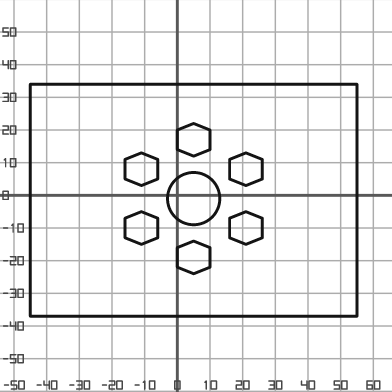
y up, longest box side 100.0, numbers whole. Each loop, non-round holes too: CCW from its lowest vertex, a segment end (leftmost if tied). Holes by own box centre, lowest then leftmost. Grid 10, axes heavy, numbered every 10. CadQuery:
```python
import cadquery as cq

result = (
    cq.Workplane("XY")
    .moveTo(-45.0, -37.0)
    .lineTo(55.0, -37.0)
    .lineTo(55.0, 34.0)
    .lineTo(-45.0, 34.0)
    .close()
    .moveTo(5.0, -24.0)
    .lineTo(10.0, -22.0)
    .lineTo(10.0, -16.0)
    .lineTo(5.0, -14.0)
    .lineTo(0.0, -16.0)
    .lineTo(0.0, -22.0)
    .close()
    .moveTo(-11.0, -15.0)
    .lineTo(-6.0, -13.0)
    .lineTo(-6.0, -7.0)
    .lineTo(-11.0, -5.0)
    .lineTo(-16.0, -7.0)
    .lineTo(-16.0, -13.0)
    .close()
    .moveTo(21.0, -15.0)
    .lineTo(26.0, -13.0)
    .lineTo(26.0, -7.0)
    .lineTo(21.0, -5.0)
    .lineTo(16.0, -7.0)
    .lineTo(16.0, -13.0)
    .close()
    .moveTo(5.0, -1.0)
    .circle(8.0)
    .moveTo(-11.0, 3.0)
    .lineTo(-6.0, 5.0)
    .lineTo(-6.0, 11.0)
    .lineTo(-11.0, 13.0)
    .lineTo(-16.0, 11.0)
    .lineTo(-16.0, 5.0)
    .close()
    .moveTo(21.0, 3.0)
    .lineTo(26.0, 5.0)
    .lineTo(26.0, 11.0)
    .lineTo(21.0, 13.0)
    .lineTo(16.0, 11.0)
    .lineTo(16.0, 5.0)
    .close()
    .moveTo(5.0, 12.0)
    .lineTo(10.0, 14.0)
    .lineTo(10.0, 20.0)
    .lineTo(5.0, 22.0)
    .lineTo(0.0, 20.0)
    .lineTo(0.0, 14.0)
    .close()
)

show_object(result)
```